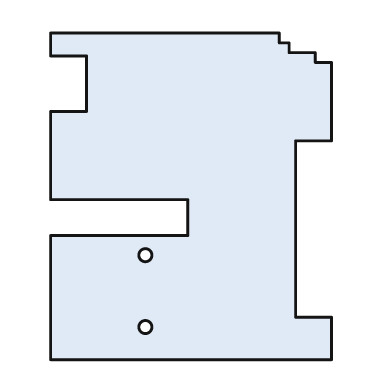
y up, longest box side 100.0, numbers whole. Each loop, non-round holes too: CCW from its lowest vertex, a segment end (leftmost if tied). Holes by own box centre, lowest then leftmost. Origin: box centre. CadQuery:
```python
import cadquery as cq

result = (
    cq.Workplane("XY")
    .moveTo(-43.0, -50.0)
    .lineTo(43.0, -50.0)
    .lineTo(43.0, -37.0)
    .lineTo(32.0, -37.0)
    .lineTo(32.0, 17.0)
    .lineTo(43.0, 17.0)
    .lineTo(43.0, 41.0)
    .lineTo(38.0, 41.0)
    .lineTo(38.0, 44.0)
    .lineTo(30.0, 44.0)
    .lineTo(30.0, 47.0)
    .lineTo(27.0, 47.0)
    .lineTo(27.0, 50.0)
    .lineTo(-43.0, 50.0)
    .lineTo(-43.0, 43.0)
    .lineTo(-32.0, 43.0)
    .lineTo(-32.0, 26.0)
    .lineTo(-43.0, 26.0)
    .lineTo(-43.0, -1.0)
    .lineTo(-1.0, -1.0)
    .lineTo(-1.0, -12.0)
    .lineTo(-43.0, -12.0)
    .close()
    .moveTo(-14.0, -40.0)
    .circle(2.0)
    .moveTo(-14.0, -18.0)
    .circle(2.0)
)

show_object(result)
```